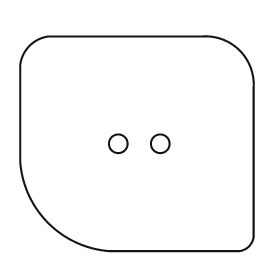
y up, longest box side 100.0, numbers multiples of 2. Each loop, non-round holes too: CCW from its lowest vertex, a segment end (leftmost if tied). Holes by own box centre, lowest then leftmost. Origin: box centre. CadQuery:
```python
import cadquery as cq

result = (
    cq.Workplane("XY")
    .moveTo(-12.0, -46.0)
    .lineTo(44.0, -46.0)
    .threePointArc((48.0, -44.0), (50.0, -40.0))
    .lineTo(50.0, 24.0)
    .threePointArc((44.0, 40.0), (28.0, 46.0))
    .lineTo(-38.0, 46.0)
    .threePointArc((-46.0, 42.0), (-50.0, 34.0))
    .lineTo(-50.0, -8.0)
    .threePointArc((-38.0, -34.0), (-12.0, -46.0))
    .close()
    .moveTo(-8.0, 0.0)
    .circle(4.0)
    .moveTo(10.0, 0.0)
    .circle(4.0)
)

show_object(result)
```